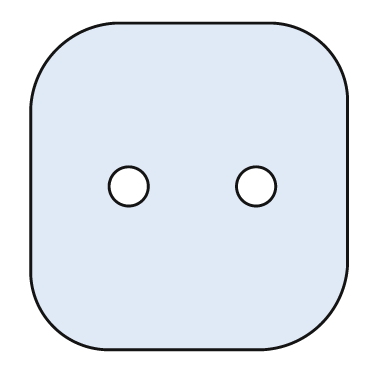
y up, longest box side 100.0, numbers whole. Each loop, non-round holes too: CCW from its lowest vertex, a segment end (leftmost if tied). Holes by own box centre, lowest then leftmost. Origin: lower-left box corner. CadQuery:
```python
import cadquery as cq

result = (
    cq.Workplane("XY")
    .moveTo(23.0, 0.0)
    .lineTo(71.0, 0.0)
    .threePointArc((89.0, 8.0), (97.0, 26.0))
    .lineTo(97.0, 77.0)
    .threePointArc((90.0, 93.0), (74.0, 100.0))
    .lineTo(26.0, 100.0)
    .threePointArc((8.0, 92.0), (0.0, 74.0))
    .lineTo(0.0, 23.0)
    .threePointArc((7.0, 7.0), (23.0, 0.0))
    .close()
    .moveTo(30.0, 50.0)
    .circle(6.0)
    .moveTo(69.0, 50.0)
    .circle(6.0)
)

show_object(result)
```